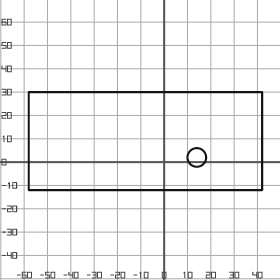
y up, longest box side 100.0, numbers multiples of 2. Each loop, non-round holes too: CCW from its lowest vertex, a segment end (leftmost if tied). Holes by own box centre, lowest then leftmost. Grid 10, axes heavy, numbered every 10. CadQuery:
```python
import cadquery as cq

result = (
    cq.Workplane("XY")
    .moveTo(-58.0, -12.0)
    .lineTo(42.0, -12.0)
    .lineTo(42.0, 30.0)
    .lineTo(-58.0, 30.0)
    .close()
    .moveTo(14.0, 2.0)
    .circle(4.0)
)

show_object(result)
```